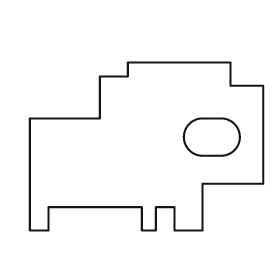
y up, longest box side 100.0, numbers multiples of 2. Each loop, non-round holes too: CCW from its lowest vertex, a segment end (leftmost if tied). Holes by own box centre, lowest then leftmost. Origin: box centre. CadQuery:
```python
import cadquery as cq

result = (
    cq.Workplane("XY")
    .moveTo(-50.0, -36.0)
    .lineTo(-42.0, -36.0)
    .lineTo(-42.0, -26.0)
    .lineTo(-2.0, -26.0)
    .lineTo(-2.0, -36.0)
    .lineTo(4.0, -36.0)
    .lineTo(4.0, -26.0)
    .lineTo(12.0, -26.0)
    .lineTo(12.0, -36.0)
    .lineTo(24.0, -36.0)
    .lineTo(24.0, -16.0)
    .lineTo(50.0, -16.0)
    .lineTo(50.0, 26.0)
    .lineTo(36.0, 26.0)
    .lineTo(36.0, 36.0)
    .lineTo(-8.0, 36.0)
    .lineTo(-8.0, 30.0)
    .lineTo(-20.0, 30.0)
    .lineTo(-20.0, 12.0)
    .lineTo(-50.0, 12.0)
    .close()
    .moveTo(24.0, -4.0)
    .lineTo(32.0, -4.0)
    .threePointArc((40.0, 4.0), (32.0, 12.0))
    .lineTo(24.0, 12.0)
    .threePointArc((16.0, 4.0), (24.0, -4.0))
    .close()
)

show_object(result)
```